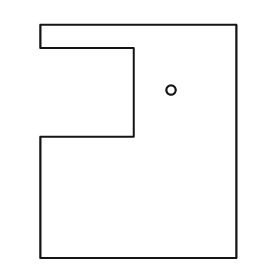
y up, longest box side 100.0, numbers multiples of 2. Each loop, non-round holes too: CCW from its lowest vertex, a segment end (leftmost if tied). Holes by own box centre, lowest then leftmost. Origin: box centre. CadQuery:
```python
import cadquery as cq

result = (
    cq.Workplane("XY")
    .moveTo(-42.0, -50.0)
    .lineTo(42.0, -50.0)
    .lineTo(42.0, 50.0)
    .lineTo(-42.0, 50.0)
    .lineTo(-42.0, 40.0)
    .lineTo(-2.0, 40.0)
    .lineTo(-2.0, 2.0)
    .lineTo(-42.0, 2.0)
    .close()
    .moveTo(14.0, 22.0)
    .circle(2.0)
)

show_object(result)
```